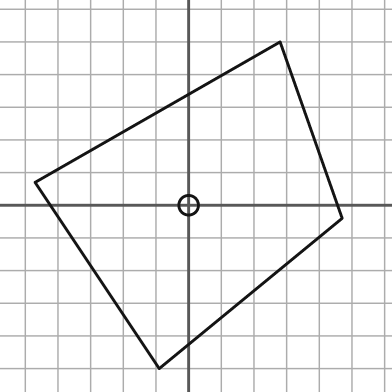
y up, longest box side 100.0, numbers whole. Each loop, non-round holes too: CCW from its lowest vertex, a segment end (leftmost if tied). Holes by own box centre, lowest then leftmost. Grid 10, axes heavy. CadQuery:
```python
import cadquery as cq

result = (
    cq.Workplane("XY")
    .moveTo(-9.0, -50.0)
    .lineTo(47.0, -4.0)
    .lineTo(28.0, 50.0)
    .lineTo(-47.0, 7.0)
    .close()
    .moveTo(0.0, 0.0)
    .circle(3.0)
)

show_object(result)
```